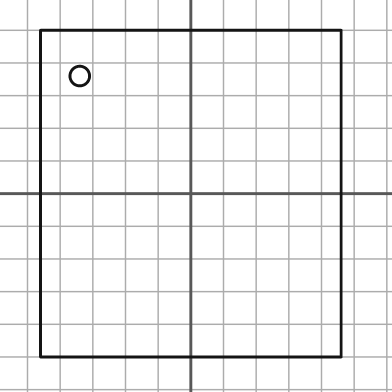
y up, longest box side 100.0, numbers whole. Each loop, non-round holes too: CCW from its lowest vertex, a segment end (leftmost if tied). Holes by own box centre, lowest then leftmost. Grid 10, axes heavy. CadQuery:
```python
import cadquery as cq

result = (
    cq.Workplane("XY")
    .moveTo(-46.0, -50.0)
    .lineTo(46.0, -50.0)
    .lineTo(46.0, 50.0)
    .lineTo(-46.0, 50.0)
    .close()
    .moveTo(-34.0, 36.0)
    .circle(3.0)
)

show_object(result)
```